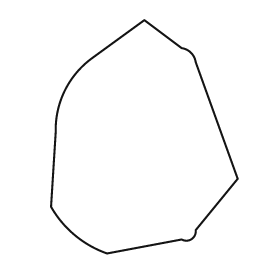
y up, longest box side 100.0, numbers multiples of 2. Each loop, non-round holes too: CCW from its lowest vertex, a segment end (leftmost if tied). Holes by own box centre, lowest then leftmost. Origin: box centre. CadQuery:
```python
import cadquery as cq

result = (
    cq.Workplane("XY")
    .moveTo(-16.0, -50.0)
    .lineTo(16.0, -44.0)
    .threePointArc((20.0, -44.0), (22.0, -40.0))
    .lineTo(40.0, -18.0)
    .lineTo(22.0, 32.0)
    .threePointArc((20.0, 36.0), (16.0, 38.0))
    .lineTo(0.0, 50.0)
    .lineTo(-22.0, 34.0)
    .threePointArc((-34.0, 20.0), (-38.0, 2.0))
    .lineTo(-40.0, -30.0)
    .threePointArc((-30.0, -42.0), (-16.0, -50.0))
    .close()
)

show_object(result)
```